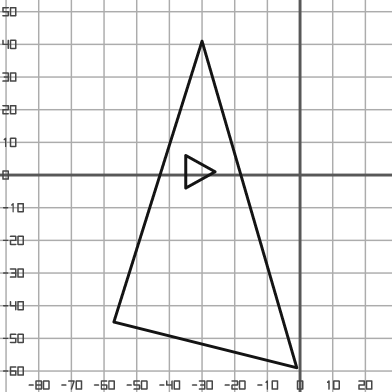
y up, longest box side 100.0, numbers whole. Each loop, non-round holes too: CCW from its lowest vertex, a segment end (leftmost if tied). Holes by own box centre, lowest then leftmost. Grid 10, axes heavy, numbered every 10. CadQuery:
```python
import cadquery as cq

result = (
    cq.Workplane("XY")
    .moveTo(-1.0, -59.0)
    .lineTo(-30.0, 41.0)
    .lineTo(-57.0, -45.0)
    .close()
    .moveTo(-35.0, -4.0)
    .lineTo(-26.0, 1.0)
    .lineTo(-35.0, 6.0)
    .close()
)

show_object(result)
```